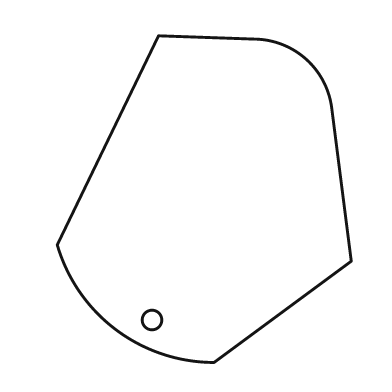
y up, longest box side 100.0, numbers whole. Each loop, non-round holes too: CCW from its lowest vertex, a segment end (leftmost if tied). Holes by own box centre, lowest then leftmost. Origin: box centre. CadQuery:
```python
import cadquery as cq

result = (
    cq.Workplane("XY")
    .moveTo(3.0, -50.0)
    .lineTo(45.0, -19.0)
    .lineTo(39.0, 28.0)
    .threePointArc((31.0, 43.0), (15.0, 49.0))
    .lineTo(-14.0, 50.0)
    .lineTo(-45.0, -14.0)
    .threePointArc((-27.0, -40.0), (3.0, -50.0))
    .close()
    .moveTo(-16.0, -37.0)
    .circle(3.0)
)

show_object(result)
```